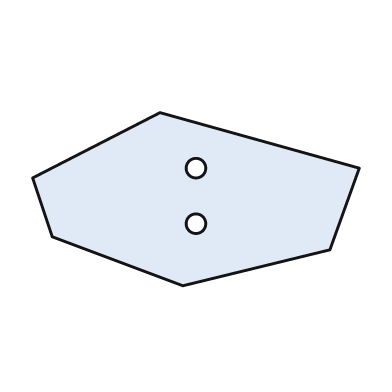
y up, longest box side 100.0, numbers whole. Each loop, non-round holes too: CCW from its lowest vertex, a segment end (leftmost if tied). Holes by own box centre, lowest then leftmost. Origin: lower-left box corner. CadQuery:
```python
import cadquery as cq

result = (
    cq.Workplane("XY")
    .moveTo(46.0, 0.0)
    .lineTo(91.0, 11.0)
    .lineTo(100.0, 36.0)
    .lineTo(39.0, 53.0)
    .lineTo(0.0, 33.0)
    .lineTo(6.0, 15.0)
    .close()
    .moveTo(50.0, 19.0)
    .circle(3.0)
    .moveTo(50.0, 36.0)
    .circle(3.0)
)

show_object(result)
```